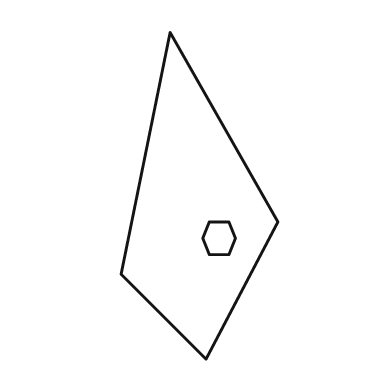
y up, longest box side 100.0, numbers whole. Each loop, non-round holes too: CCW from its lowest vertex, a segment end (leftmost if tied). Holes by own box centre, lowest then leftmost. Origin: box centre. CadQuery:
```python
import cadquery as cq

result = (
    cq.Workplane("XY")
    .moveTo(2.0, -50.0)
    .lineTo(24.0, -8.0)
    .lineTo(-9.0, 50.0)
    .lineTo(-24.0, -24.0)
    .close()
    .moveTo(3.0, -18.0)
    .lineTo(9.0, -18.0)
    .lineTo(11.0, -13.0)
    .lineTo(9.0, -8.0)
    .lineTo(3.0, -8.0)
    .lineTo(1.0, -13.0)
    .close()
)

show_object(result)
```